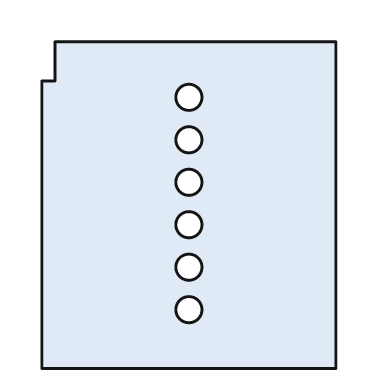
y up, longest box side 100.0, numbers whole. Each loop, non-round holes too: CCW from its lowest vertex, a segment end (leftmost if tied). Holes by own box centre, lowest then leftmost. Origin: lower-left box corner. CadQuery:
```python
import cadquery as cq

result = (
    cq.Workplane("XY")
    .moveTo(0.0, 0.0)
    .lineTo(90.0, 0.0)
    .lineTo(90.0, 100.0)
    .lineTo(4.0, 100.0)
    .lineTo(4.0, 88.0)
    .lineTo(0.0, 88.0)
    .close()
    .moveTo(45.0, 18.0)
    .circle(4.0)
    .moveTo(45.0, 31.0)
    .circle(4.0)
    .moveTo(45.0, 44.0)
    .circle(4.0)
    .moveTo(45.0, 57.0)
    .circle(4.0)
    .moveTo(45.0, 70.0)
    .circle(4.0)
    .moveTo(45.0, 83.0)
    .circle(4.0)
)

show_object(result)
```